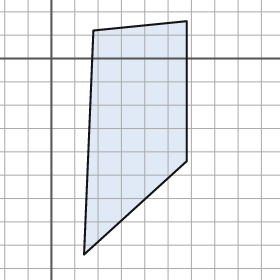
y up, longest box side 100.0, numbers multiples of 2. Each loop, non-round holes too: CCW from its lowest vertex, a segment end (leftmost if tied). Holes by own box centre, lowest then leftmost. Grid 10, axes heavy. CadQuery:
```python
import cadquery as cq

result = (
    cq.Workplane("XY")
    .moveTo(14.0, -84.0)
    .lineTo(58.0, -44.0)
    .lineTo(58.0, 16.0)
    .lineTo(18.0, 12.0)
    .close()
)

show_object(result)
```